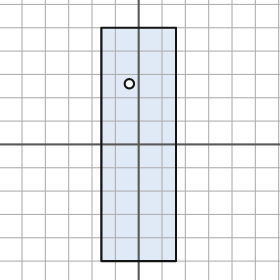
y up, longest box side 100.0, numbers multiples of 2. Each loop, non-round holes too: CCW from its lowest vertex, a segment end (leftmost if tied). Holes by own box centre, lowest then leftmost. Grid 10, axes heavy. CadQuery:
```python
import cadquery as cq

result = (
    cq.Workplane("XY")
    .moveTo(-16.0, -50.0)
    .lineTo(16.0, -50.0)
    .lineTo(16.0, 50.0)
    .lineTo(-16.0, 50.0)
    .close()
    .moveTo(-4.0, 26.0)
    .circle(2.0)
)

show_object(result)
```